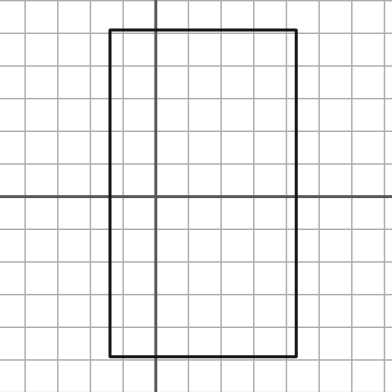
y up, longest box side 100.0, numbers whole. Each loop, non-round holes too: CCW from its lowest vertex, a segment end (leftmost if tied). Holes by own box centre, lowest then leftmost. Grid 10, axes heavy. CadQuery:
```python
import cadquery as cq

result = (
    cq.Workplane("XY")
    .moveTo(-14.0, -49.0)
    .lineTo(43.0, -49.0)
    .lineTo(43.0, 51.0)
    .lineTo(-14.0, 51.0)
    .close()
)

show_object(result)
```